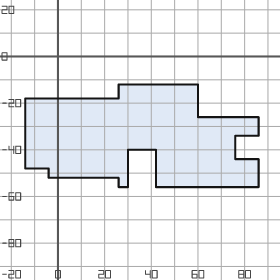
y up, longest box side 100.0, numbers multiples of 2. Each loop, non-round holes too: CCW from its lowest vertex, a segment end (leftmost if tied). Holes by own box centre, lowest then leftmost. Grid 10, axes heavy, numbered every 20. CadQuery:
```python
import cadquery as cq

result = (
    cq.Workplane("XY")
    .moveTo(26.0, -56.0)
    .lineTo(30.0, -56.0)
    .lineTo(30.0, -40.0)
    .lineTo(42.0, -40.0)
    .lineTo(42.0, -56.0)
    .lineTo(86.0, -56.0)
    .lineTo(86.0, -44.0)
    .lineTo(76.0, -44.0)
    .lineTo(76.0, -34.0)
    .lineTo(86.0, -34.0)
    .lineTo(86.0, -26.0)
    .lineTo(60.0, -26.0)
    .lineTo(60.0, -12.0)
    .lineTo(26.0, -12.0)
    .lineTo(26.0, -18.0)
    .lineTo(-14.0, -18.0)
    .lineTo(-14.0, -48.0)
    .lineTo(-4.0, -48.0)
    .lineTo(-4.0, -52.0)
    .lineTo(26.0, -52.0)
    .close()
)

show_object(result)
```